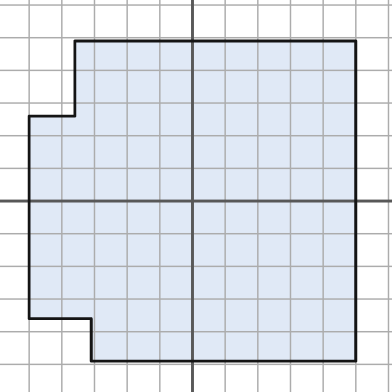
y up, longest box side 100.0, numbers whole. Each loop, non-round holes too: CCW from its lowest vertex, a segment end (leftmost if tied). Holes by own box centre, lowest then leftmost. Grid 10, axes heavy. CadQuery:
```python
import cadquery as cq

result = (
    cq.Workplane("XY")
    .moveTo(-31.0, -49.0)
    .lineTo(50.0, -49.0)
    .lineTo(50.0, 49.0)
    .lineTo(-36.0, 49.0)
    .lineTo(-36.0, 26.0)
    .lineTo(-50.0, 26.0)
    .lineTo(-50.0, -36.0)
    .lineTo(-31.0, -36.0)
    .close()
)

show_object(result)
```